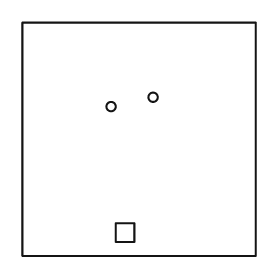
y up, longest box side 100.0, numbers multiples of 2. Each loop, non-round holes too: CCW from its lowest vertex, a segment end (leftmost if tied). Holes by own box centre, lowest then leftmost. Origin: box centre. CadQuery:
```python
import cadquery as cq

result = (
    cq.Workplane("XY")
    .moveTo(-50.0, -50.0)
    .lineTo(50.0, -50.0)
    .lineTo(50.0, 50.0)
    .lineTo(-50.0, 50.0)
    .close()
    .moveTo(-10.0, -44.0)
    .lineTo(-2.0, -44.0)
    .lineTo(-2.0, -36.0)
    .lineTo(-10.0, -36.0)
    .close()
    .moveTo(-12.0, 14.0)
    .circle(2.0)
    .moveTo(6.0, 18.0)
    .circle(2.0)
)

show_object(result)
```